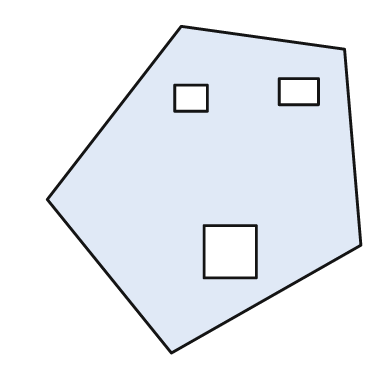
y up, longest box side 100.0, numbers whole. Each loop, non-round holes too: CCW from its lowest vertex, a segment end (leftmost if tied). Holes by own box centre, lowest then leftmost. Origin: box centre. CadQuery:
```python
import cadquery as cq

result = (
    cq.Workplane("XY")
    .moveTo(-10.0, -50.0)
    .lineTo(48.0, -17.0)
    .lineTo(43.0, 43.0)
    .lineTo(-7.0, 50.0)
    .lineTo(-48.0, -3.0)
    .close()
    .moveTo(0.0, -27.0)
    .lineTo(16.0, -27.0)
    .lineTo(16.0, -11.0)
    .lineTo(0.0, -11.0)
    .close()
    .moveTo(-9.0, 24.0)
    .lineTo(1.0, 24.0)
    .lineTo(1.0, 32.0)
    .lineTo(-9.0, 32.0)
    .close()
    .moveTo(23.0, 26.0)
    .lineTo(35.0, 26.0)
    .lineTo(35.0, 34.0)
    .lineTo(23.0, 34.0)
    .close()
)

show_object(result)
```